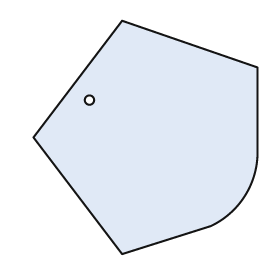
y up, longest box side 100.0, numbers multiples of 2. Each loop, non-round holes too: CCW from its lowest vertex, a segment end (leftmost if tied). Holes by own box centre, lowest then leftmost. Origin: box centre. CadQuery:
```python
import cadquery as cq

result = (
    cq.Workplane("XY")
    .moveTo(-10.0, -50.0)
    .lineTo(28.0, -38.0)
    .threePointArc((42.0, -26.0), (48.0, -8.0))
    .lineTo(48.0, 30.0)
    .lineTo(-10.0, 50.0)
    .lineTo(-48.0, 0.0)
    .close()
    .moveTo(-24.0, 16.0)
    .circle(2.0)
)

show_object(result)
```